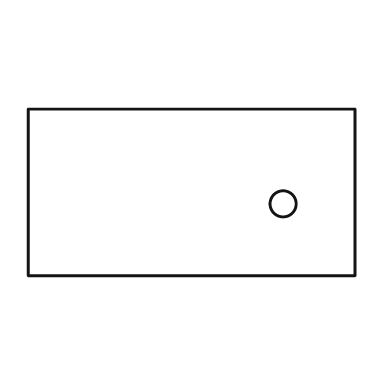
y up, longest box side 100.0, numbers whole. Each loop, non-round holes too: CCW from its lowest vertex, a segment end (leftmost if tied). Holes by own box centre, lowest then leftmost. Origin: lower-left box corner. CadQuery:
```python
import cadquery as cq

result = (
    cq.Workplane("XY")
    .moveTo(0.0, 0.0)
    .lineTo(100.0, 0.0)
    .lineTo(100.0, 51.0)
    .lineTo(0.0, 51.0)
    .close()
    .moveTo(78.0, 22.0)
    .circle(4.0)
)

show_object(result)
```